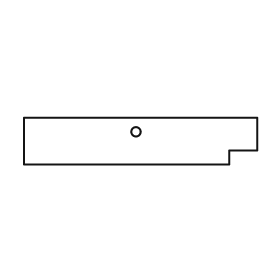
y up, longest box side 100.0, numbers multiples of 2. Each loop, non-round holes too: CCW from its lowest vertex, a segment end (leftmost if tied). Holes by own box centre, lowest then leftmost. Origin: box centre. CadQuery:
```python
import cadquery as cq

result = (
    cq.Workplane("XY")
    .moveTo(-50.0, -10.0)
    .lineTo(38.0, -10.0)
    .lineTo(38.0, -4.0)
    .lineTo(50.0, -4.0)
    .lineTo(50.0, 10.0)
    .lineTo(-50.0, 10.0)
    .close()
    .moveTo(-2.0, 4.0)
    .circle(2.0)
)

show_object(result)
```